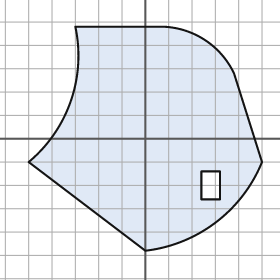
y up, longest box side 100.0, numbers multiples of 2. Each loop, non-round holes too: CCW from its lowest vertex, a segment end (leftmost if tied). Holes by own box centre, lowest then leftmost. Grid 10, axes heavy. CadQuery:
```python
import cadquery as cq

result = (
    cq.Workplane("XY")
    .moveTo(0.0, -48.0)
    .threePointArc((30.0, -36.0), (50.0, -10.0))
    .lineTo(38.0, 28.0)
    .threePointArc((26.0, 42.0), (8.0, 48.0))
    .lineTo(-30.0, 48.0)
    .threePointArc((-32.0, 16.0), (-50.0, -10.0))
    .close()
    .moveTo(24.0, -26.0)
    .lineTo(32.0, -26.0)
    .lineTo(32.0, -14.0)
    .lineTo(24.0, -14.0)
    .close()
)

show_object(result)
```